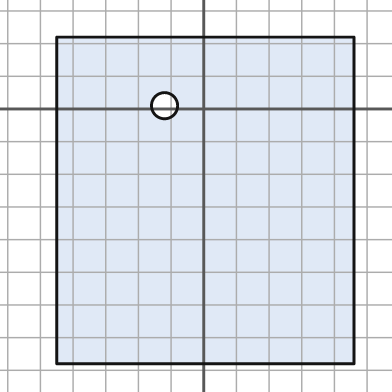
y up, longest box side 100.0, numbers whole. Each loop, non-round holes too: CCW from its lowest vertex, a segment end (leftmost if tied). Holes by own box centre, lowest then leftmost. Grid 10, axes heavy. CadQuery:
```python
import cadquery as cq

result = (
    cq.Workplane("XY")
    .moveTo(-45.0, -78.0)
    .lineTo(46.0, -78.0)
    .lineTo(46.0, 22.0)
    .lineTo(-45.0, 22.0)
    .close()
    .moveTo(-12.0, 1.0)
    .circle(4.0)
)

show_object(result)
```